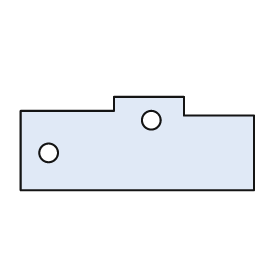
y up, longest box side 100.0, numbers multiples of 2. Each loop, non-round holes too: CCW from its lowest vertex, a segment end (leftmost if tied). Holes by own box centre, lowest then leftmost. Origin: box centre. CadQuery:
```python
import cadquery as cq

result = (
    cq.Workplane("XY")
    .moveTo(-50.0, -20.0)
    .lineTo(50.0, -20.0)
    .lineTo(50.0, 12.0)
    .lineTo(20.0, 12.0)
    .lineTo(20.0, 20.0)
    .lineTo(-10.0, 20.0)
    .lineTo(-10.0, 14.0)
    .lineTo(-50.0, 14.0)
    .close()
    .moveTo(-38.0, -4.0)
    .circle(4.0)
    .moveTo(6.0, 10.0)
    .circle(4.0)
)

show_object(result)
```